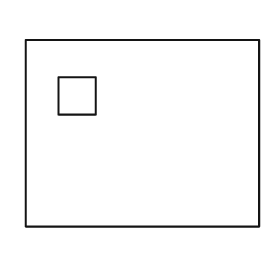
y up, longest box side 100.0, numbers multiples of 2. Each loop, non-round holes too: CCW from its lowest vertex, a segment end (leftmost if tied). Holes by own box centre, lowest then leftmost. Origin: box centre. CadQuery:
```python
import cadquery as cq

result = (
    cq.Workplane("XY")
    .moveTo(-50.0, -40.0)
    .lineTo(50.0, -40.0)
    .lineTo(50.0, 40.0)
    .lineTo(-50.0, 40.0)
    .close()
    .moveTo(-36.0, 8.0)
    .lineTo(-20.0, 8.0)
    .lineTo(-20.0, 24.0)
    .lineTo(-36.0, 24.0)
    .close()
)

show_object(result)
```